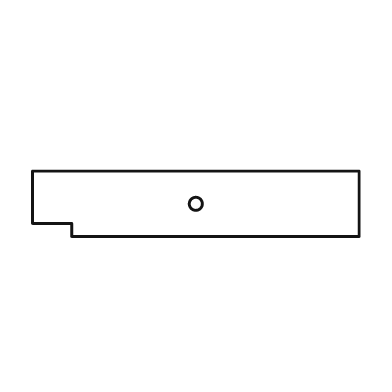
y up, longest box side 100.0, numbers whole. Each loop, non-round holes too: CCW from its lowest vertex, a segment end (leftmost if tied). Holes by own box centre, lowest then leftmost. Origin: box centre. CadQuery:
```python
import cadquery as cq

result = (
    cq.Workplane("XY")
    .moveTo(-38.0, -10.0)
    .lineTo(50.0, -10.0)
    .lineTo(50.0, 10.0)
    .lineTo(-50.0, 10.0)
    .lineTo(-50.0, -6.0)
    .lineTo(-38.0, -6.0)
    .close()
    .moveTo(0.0, 0.0)
    .circle(2.0)
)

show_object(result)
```